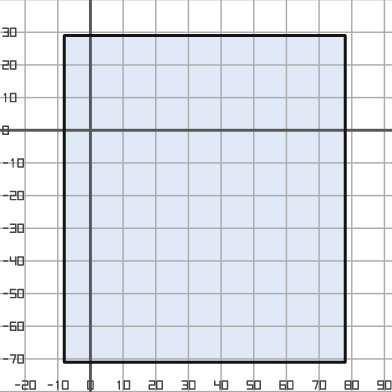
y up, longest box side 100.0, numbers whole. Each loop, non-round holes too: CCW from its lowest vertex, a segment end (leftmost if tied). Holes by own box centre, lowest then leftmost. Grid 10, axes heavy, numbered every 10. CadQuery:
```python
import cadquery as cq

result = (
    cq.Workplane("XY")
    .moveTo(-8.0, -71.0)
    .lineTo(78.0, -71.0)
    .lineTo(78.0, 29.0)
    .lineTo(-8.0, 29.0)
    .close()
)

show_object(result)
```